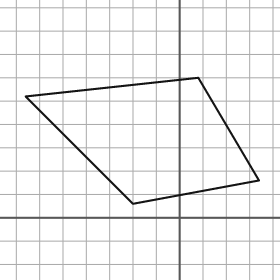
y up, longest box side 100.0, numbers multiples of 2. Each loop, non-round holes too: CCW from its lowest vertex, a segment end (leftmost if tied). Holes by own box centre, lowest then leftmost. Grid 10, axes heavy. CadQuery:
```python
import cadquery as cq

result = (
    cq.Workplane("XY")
    .moveTo(-20.0, 6.0)
    .lineTo(34.0, 16.0)
    .lineTo(8.0, 60.0)
    .lineTo(-66.0, 52.0)
    .close()
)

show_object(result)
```